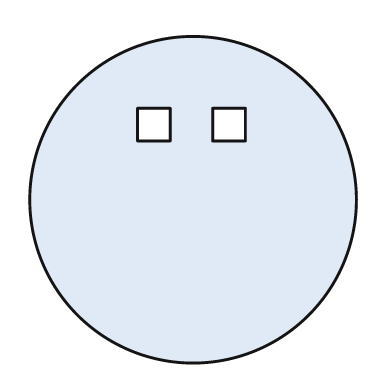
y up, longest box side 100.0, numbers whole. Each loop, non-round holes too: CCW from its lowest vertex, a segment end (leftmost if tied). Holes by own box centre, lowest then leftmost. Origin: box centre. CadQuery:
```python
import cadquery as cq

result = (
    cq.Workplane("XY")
    .moveTo(0.0, 0.0)
    .circle(50.0)
    .moveTo(-17.0, 18.0)
    .lineTo(-7.0, 18.0)
    .lineTo(-7.0, 28.0)
    .lineTo(-17.0, 28.0)
    .close()
    .moveTo(6.0, 18.0)
    .lineTo(16.0, 18.0)
    .lineTo(16.0, 28.0)
    .lineTo(6.0, 28.0)
    .close()
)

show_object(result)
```